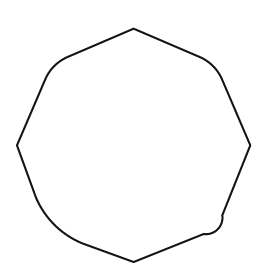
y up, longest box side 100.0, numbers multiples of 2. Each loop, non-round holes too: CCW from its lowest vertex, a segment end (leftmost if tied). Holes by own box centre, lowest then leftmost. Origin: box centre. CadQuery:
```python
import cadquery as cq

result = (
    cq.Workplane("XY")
    .moveTo(0.0, -50.0)
    .lineTo(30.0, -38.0)
    .threePointArc((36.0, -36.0), (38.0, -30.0))
    .lineTo(50.0, 0.0)
    .lineTo(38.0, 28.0)
    .threePointArc((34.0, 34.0), (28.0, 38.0))
    .lineTo(0.0, 50.0)
    .lineTo(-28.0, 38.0)
    .threePointArc((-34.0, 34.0), (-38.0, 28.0))
    .lineTo(-50.0, 0.0)
    .lineTo(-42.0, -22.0)
    .threePointArc((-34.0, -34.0), (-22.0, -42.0))
    .close()
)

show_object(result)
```